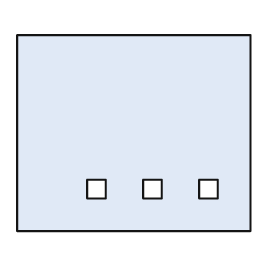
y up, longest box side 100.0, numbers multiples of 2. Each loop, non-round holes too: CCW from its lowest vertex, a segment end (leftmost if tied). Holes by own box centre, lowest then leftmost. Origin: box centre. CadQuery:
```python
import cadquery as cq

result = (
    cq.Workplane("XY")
    .moveTo(-50.0, -42.0)
    .lineTo(50.0, -42.0)
    .lineTo(50.0, 42.0)
    .lineTo(-50.0, 42.0)
    .close()
    .moveTo(-20.0, -28.0)
    .lineTo(-12.0, -28.0)
    .lineTo(-12.0, -20.0)
    .lineTo(-20.0, -20.0)
    .close()
    .moveTo(4.0, -28.0)
    .lineTo(12.0, -28.0)
    .lineTo(12.0, -20.0)
    .lineTo(4.0, -20.0)
    .close()
    .moveTo(28.0, -28.0)
    .lineTo(36.0, -28.0)
    .lineTo(36.0, -20.0)
    .lineTo(28.0, -20.0)
    .close()
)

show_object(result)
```